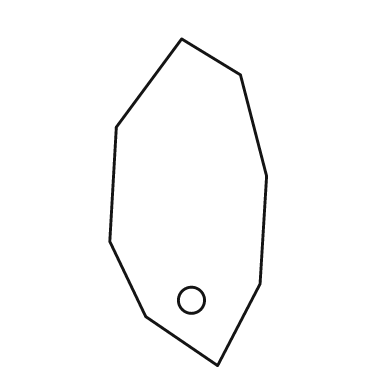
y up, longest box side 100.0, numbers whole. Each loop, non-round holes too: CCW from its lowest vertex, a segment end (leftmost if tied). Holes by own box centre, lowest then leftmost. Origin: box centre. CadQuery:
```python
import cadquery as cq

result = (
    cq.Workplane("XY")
    .moveTo(9.0, -50.0)
    .lineTo(22.0, -25.0)
    .lineTo(24.0, 8.0)
    .lineTo(16.0, 39.0)
    .lineTo(-2.0, 50.0)
    .lineTo(-22.0, 23.0)
    .lineTo(-24.0, -12.0)
    .lineTo(-13.0, -35.0)
    .close()
    .moveTo(1.0, -30.0)
    .circle(4.0)
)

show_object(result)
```